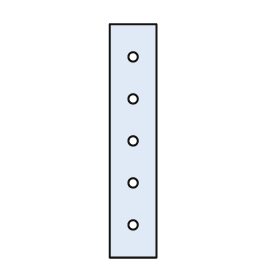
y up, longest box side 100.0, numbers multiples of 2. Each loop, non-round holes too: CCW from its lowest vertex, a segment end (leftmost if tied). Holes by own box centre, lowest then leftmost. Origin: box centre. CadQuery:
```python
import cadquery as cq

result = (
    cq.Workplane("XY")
    .moveTo(-10.0, -50.0)
    .lineTo(10.0, -50.0)
    .lineTo(10.0, 50.0)
    .lineTo(-10.0, 50.0)
    .close()
    .moveTo(0.0, -36.0)
    .circle(2.0)
    .moveTo(0.0, -18.0)
    .circle(2.0)
    .moveTo(0.0, 0.0)
    .circle(2.0)
    .moveTo(0.0, 18.0)
    .circle(2.0)
    .moveTo(0.0, 36.0)
    .circle(2.0)
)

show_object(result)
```